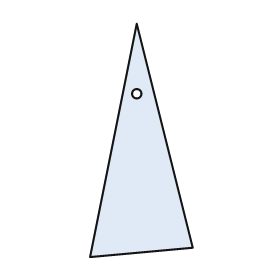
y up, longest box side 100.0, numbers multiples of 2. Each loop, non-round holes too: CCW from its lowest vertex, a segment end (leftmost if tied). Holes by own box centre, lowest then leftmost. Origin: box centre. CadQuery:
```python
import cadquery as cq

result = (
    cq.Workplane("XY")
    .moveTo(-22.0, -50.0)
    .lineTo(22.0, -46.0)
    .lineTo(-2.0, 50.0)
    .close()
    .moveTo(-2.0, 20.0)
    .circle(2.0)
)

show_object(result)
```